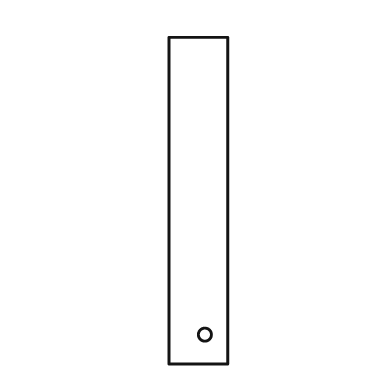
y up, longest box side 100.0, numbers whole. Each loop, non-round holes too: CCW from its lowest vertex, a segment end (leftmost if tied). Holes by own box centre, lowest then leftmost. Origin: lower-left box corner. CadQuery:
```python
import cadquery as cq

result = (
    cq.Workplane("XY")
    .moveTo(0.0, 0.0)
    .lineTo(18.0, 0.0)
    .lineTo(18.0, 100.0)
    .lineTo(0.0, 100.0)
    .close()
    .moveTo(11.0, 9.0)
    .circle(2.0)
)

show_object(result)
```